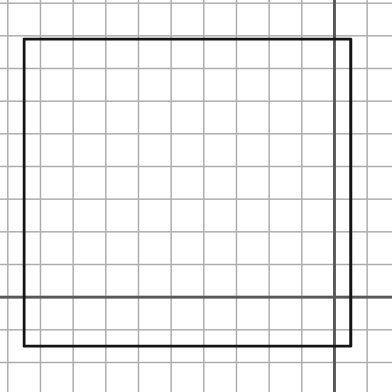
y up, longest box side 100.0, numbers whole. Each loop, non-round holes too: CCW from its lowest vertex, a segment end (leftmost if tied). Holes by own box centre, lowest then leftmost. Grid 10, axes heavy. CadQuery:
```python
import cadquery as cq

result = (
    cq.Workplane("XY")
    .moveTo(-95.0, -15.0)
    .lineTo(5.0, -15.0)
    .lineTo(5.0, 79.0)
    .lineTo(-95.0, 79.0)
    .close()
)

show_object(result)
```